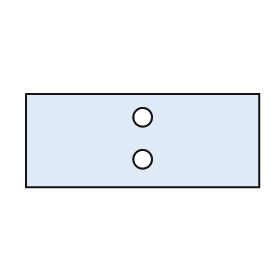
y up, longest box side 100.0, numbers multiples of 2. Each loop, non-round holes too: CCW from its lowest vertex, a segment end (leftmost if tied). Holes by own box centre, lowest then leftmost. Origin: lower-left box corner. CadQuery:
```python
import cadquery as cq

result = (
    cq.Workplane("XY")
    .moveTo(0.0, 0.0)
    .lineTo(100.0, 0.0)
    .lineTo(100.0, 40.0)
    .lineTo(0.0, 40.0)
    .close()
    .moveTo(50.0, 12.0)
    .circle(4.0)
    .moveTo(50.0, 30.0)
    .circle(4.0)
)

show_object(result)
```